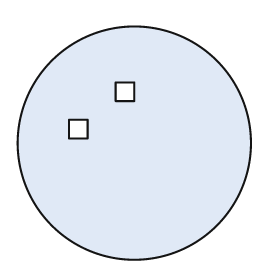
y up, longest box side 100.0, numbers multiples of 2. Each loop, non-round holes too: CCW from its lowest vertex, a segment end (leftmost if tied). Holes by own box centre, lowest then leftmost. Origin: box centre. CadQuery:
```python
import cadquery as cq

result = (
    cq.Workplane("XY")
    .moveTo(0.0, 0.0)
    .circle(50.0)
    .moveTo(-28.0, 2.0)
    .lineTo(-20.0, 2.0)
    .lineTo(-20.0, 10.0)
    .lineTo(-28.0, 10.0)
    .close()
    .moveTo(-8.0, 18.0)
    .lineTo(0.0, 18.0)
    .lineTo(0.0, 26.0)
    .lineTo(-8.0, 26.0)
    .close()
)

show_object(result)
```